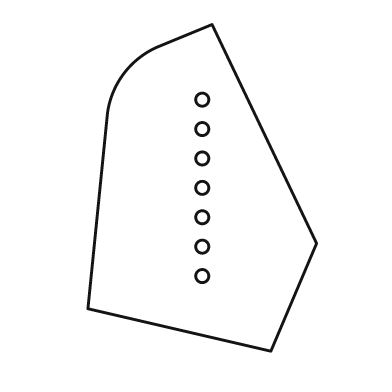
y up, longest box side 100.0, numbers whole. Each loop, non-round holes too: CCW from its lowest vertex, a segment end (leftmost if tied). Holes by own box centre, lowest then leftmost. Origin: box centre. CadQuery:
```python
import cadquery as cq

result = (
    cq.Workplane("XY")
    .moveTo(21.0, -50.0)
    .lineTo(35.0, -17.0)
    .lineTo(3.0, 50.0)
    .lineTo(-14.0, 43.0)
    .threePointArc((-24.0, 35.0), (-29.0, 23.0))
    .lineTo(-35.0, -37.0)
    .close()
    .moveTo(0.0, -27.0)
    .circle(2.0)
    .moveTo(0.0, -18.0)
    .circle(2.0)
    .moveTo(0.0, -9.0)
    .circle(2.0)
    .moveTo(0.0, 0.0)
    .circle(2.0)
    .moveTo(0.0, 9.0)
    .circle(2.0)
    .moveTo(0.0, 18.0)
    .circle(2.0)
    .moveTo(0.0, 27.0)
    .circle(2.0)
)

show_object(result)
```